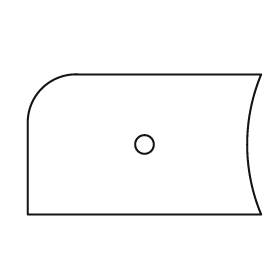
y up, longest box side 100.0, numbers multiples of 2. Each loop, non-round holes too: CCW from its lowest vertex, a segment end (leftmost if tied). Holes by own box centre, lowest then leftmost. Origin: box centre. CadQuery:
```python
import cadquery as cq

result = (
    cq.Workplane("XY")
    .moveTo(-50.0, -30.0)
    .lineTo(50.0, -30.0)
    .threePointArc((44.0, 0.0), (50.0, 30.0))
    .lineTo(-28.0, 30.0)
    .threePointArc((-44.0, 24.0), (-50.0, 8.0))
    .close()
    .moveTo(0.0, 0.0)
    .circle(4.0)
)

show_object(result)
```